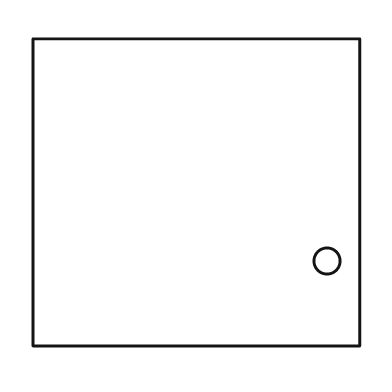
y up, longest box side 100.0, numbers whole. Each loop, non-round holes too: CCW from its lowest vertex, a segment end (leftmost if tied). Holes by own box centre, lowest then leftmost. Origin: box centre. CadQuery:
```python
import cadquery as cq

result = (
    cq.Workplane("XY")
    .moveTo(-50.0, -47.0)
    .lineTo(50.0, -47.0)
    .lineTo(50.0, 47.0)
    .lineTo(-50.0, 47.0)
    .close()
    .moveTo(40.0, -21.0)
    .circle(4.0)
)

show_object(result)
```